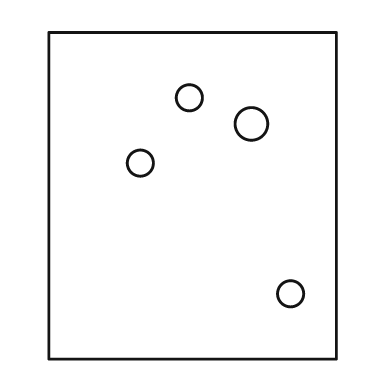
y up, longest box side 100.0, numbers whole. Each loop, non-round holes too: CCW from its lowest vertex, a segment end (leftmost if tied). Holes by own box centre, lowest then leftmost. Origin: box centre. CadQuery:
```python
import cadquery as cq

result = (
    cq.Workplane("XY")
    .moveTo(-44.0, -50.0)
    .lineTo(44.0, -50.0)
    .lineTo(44.0, 50.0)
    .lineTo(-44.0, 50.0)
    .close()
    .moveTo(30.0, -30.0)
    .circle(4.0)
    .moveTo(-16.0, 10.0)
    .circle(4.0)
    .moveTo(18.0, 22.0)
    .circle(5.0)
    .moveTo(-1.0, 30.0)
    .circle(4.0)
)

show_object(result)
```